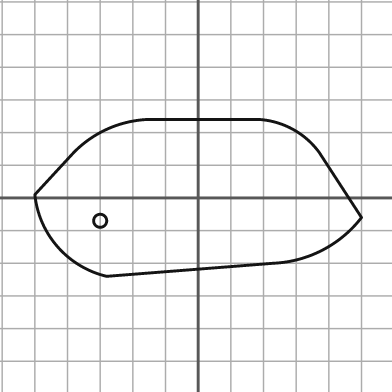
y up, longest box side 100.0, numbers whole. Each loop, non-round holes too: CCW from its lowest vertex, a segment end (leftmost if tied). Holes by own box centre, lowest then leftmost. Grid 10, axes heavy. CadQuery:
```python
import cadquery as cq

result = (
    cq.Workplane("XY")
    .moveTo(-28.0, -24.0)
    .lineTo(23.0, -20.0)
    .threePointArc((38.0, -16.0), (50.0, -6.0))
    .lineTo(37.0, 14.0)
    .threePointArc((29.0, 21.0), (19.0, 24.0))
    .lineTo(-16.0, 24.0)
    .threePointArc((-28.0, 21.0), (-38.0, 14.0))
    .lineTo(-50.0, 1.0)
    .threePointArc((-43.0, -15.0), (-28.0, -24.0))
    .close()
    .moveTo(-30.0, -7.0)
    .circle(2.0)
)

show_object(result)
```